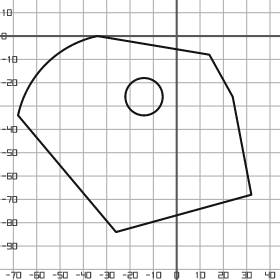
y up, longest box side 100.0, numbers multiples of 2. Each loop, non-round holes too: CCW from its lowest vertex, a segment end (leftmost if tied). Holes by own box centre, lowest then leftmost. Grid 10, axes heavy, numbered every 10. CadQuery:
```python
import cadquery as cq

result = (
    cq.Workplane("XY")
    .moveTo(-26.0, -84.0)
    .lineTo(32.0, -68.0)
    .lineTo(24.0, -26.0)
    .lineTo(14.0, -8.0)
    .lineTo(-34.0, 0.0)
    .threePointArc((-56.0, -12.0), (-68.0, -34.0))
    .close()
    .moveTo(-14.0, -26.0)
    .circle(8.0)
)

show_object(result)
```